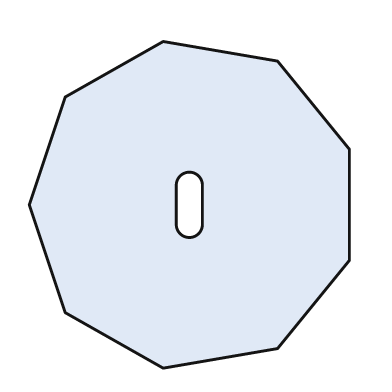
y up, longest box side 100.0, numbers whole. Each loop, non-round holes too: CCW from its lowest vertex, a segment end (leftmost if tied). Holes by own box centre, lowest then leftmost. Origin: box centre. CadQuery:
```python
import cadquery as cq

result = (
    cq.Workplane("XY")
    .moveTo(-8.0, -50.0)
    .lineTo(27.0, -44.0)
    .lineTo(49.0, -17.0)
    .lineTo(49.0, 17.0)
    .lineTo(27.0, 44.0)
    .lineTo(-8.0, 50.0)
    .lineTo(-38.0, 33.0)
    .lineTo(-49.0, 0.0)
    .lineTo(-38.0, -33.0)
    .close()
    .moveTo(-4.0, -6.0)
    .threePointArc((0.0, -10.0), (4.0, -6.0))
    .lineTo(4.0, 6.0)
    .threePointArc((0.0, 10.0), (-4.0, 6.0))
    .close()
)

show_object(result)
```